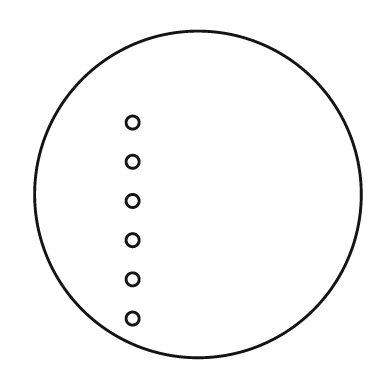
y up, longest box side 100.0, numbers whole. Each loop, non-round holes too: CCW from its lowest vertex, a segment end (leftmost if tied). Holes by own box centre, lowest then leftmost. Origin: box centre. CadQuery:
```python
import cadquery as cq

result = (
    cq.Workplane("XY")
    .moveTo(0.0, 0.0)
    .circle(50.0)
    .moveTo(-20.0, -38.0)
    .circle(2.0)
    .moveTo(-20.0, -26.0)
    .circle(2.0)
    .moveTo(-20.0, -14.0)
    .circle(2.0)
    .moveTo(-20.0, -2.0)
    .circle(2.0)
    .moveTo(-20.0, 10.0)
    .circle(2.0)
    .moveTo(-20.0, 22.0)
    .circle(2.0)
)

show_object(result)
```